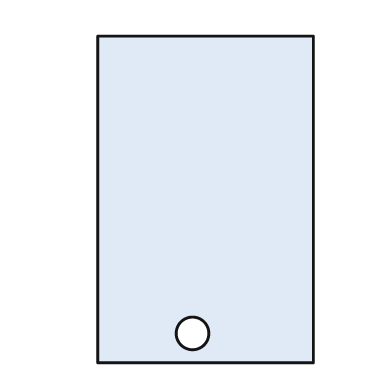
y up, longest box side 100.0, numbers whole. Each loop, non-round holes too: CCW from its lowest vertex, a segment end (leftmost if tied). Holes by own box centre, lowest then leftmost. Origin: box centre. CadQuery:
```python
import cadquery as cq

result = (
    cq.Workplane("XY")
    .moveTo(-33.0, -50.0)
    .lineTo(33.0, -50.0)
    .lineTo(33.0, 50.0)
    .lineTo(-33.0, 50.0)
    .close()
    .moveTo(-4.0, -41.0)
    .circle(5.0)
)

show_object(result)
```